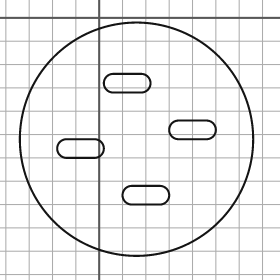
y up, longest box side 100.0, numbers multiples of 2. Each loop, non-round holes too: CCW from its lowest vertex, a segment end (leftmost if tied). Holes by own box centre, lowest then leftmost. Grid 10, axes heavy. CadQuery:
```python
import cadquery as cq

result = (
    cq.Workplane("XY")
    .moveTo(16.0, -52.0)
    .circle(50.0)
    .moveTo(14.0, -80.0)
    .lineTo(26.0, -80.0)
    .threePointArc((30.0, -76.0), (26.0, -72.0))
    .lineTo(14.0, -72.0)
    .threePointArc((10.0, -76.0), (14.0, -80.0))
    .close()
    .moveTo(-14.0, -60.0)
    .lineTo(-2.0, -60.0)
    .threePointArc((2.0, -56.0), (-2.0, -52.0))
    .lineTo(-14.0, -52.0)
    .threePointArc((-18.0, -56.0), (-14.0, -60.0))
    .close()
    .moveTo(34.0, -52.0)
    .lineTo(46.0, -52.0)
    .threePointArc((50.0, -48.0), (46.0, -44.0))
    .lineTo(34.0, -44.0)
    .threePointArc((30.0, -48.0), (34.0, -52.0))
    .close()
    .moveTo(6.0, -32.0)
    .lineTo(18.0, -32.0)
    .threePointArc((22.0, -28.0), (18.0, -24.0))
    .lineTo(6.0, -24.0)
    .threePointArc((2.0, -28.0), (6.0, -32.0))
    .close()
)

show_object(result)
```